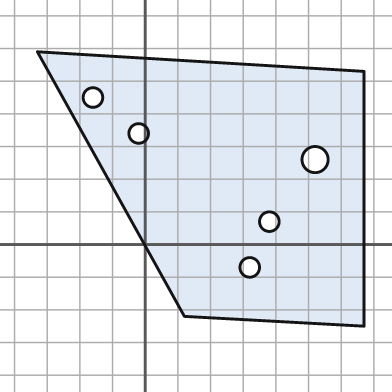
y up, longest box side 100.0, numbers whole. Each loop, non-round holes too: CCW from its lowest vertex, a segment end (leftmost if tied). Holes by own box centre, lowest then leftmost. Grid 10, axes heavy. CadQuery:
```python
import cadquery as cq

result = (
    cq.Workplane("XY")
    .moveTo(67.0, -25.0)
    .lineTo(67.0, 53.0)
    .lineTo(-33.0, 59.0)
    .lineTo(12.0, -22.0)
    .close()
    .moveTo(32.0, -7.0)
    .circle(3.0)
    .moveTo(38.0, 7.0)
    .circle(3.0)
    .moveTo(52.0, 26.0)
    .circle(4.0)
    .moveTo(-2.0, 34.0)
    .circle(3.0)
    .moveTo(-16.0, 45.0)
    .circle(3.0)
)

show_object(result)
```